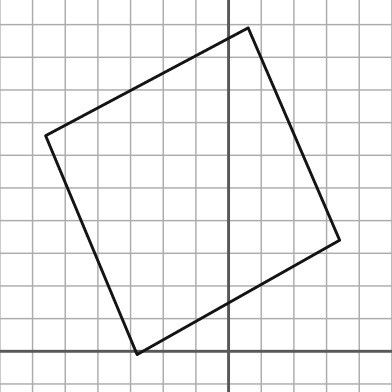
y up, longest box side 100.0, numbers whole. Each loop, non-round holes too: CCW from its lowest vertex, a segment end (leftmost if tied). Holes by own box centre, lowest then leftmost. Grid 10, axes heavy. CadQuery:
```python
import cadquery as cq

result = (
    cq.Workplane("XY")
    .moveTo(-28.0, -1.0)
    .lineTo(34.0, 34.0)
    .lineTo(6.0, 99.0)
    .lineTo(-56.0, 66.0)
    .close()
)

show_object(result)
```